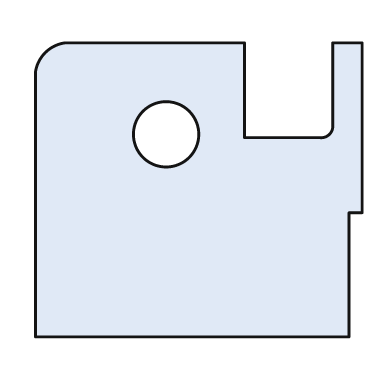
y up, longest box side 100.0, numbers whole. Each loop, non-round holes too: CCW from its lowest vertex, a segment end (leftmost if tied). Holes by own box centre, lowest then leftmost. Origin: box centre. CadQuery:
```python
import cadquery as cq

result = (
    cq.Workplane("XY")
    .moveTo(-50.0, -45.0)
    .lineTo(46.0, -45.0)
    .lineTo(46.0, -7.0)
    .lineTo(50.0, -7.0)
    .lineTo(50.0, 45.0)
    .lineTo(41.0, 45.0)
    .lineTo(41.0, 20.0)
    .threePointArc((40.0, 17.0), (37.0, 16.0))
    .lineTo(14.0, 16.0)
    .lineTo(14.0, 45.0)
    .lineTo(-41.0, 45.0)
    .threePointArc((-47.0, 42.0), (-50.0, 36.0))
    .close()
    .moveTo(-10.0, 17.0)
    .circle(10.0)
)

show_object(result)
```